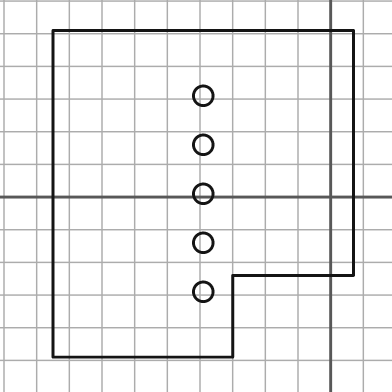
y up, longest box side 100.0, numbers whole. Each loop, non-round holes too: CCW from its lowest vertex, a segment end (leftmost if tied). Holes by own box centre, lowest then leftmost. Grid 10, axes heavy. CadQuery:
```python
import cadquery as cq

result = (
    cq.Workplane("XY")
    .moveTo(-85.0, -49.0)
    .lineTo(-30.0, -49.0)
    .lineTo(-30.0, -24.0)
    .lineTo(7.0, -24.0)
    .lineTo(7.0, 51.0)
    .lineTo(-85.0, 51.0)
    .close()
    .moveTo(-39.0, -29.0)
    .circle(3.0)
    .moveTo(-39.0, -14.0)
    .circle(3.0)
    .moveTo(-39.0, 1.0)
    .circle(3.0)
    .moveTo(-39.0, 16.0)
    .circle(3.0)
    .moveTo(-39.0, 31.0)
    .circle(3.0)
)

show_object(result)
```